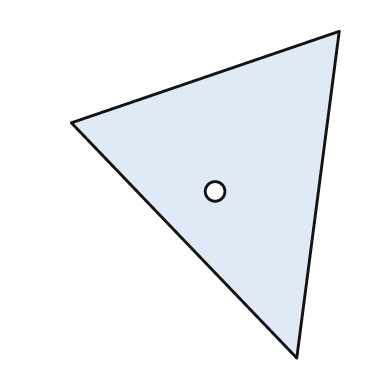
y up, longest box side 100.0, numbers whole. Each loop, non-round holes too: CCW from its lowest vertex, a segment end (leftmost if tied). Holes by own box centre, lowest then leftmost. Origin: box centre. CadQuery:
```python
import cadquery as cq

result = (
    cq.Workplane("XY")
    .moveTo(28.0, -50.0)
    .lineTo(41.0, 50.0)
    .lineTo(-41.0, 22.0)
    .close()
    .moveTo(3.0, 1.0)
    .circle(3.0)
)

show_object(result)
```